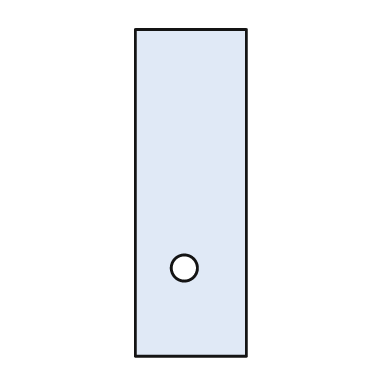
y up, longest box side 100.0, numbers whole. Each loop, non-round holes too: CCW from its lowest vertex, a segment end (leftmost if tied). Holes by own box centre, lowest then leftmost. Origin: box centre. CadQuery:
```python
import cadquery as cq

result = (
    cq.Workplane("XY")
    .moveTo(-17.0, -50.0)
    .lineTo(17.0, -50.0)
    .lineTo(17.0, 50.0)
    .lineTo(-17.0, 50.0)
    .close()
    .moveTo(-2.0, -23.0)
    .circle(4.0)
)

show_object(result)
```